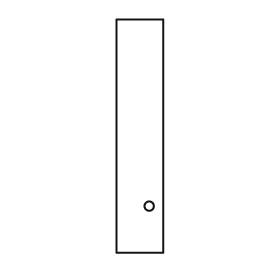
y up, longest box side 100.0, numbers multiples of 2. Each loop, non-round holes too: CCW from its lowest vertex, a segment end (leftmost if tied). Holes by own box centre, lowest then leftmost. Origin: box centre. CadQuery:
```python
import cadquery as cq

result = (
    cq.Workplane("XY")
    .moveTo(-10.0, -50.0)
    .lineTo(10.0, -50.0)
    .lineTo(10.0, 50.0)
    .lineTo(-10.0, 50.0)
    .close()
    .moveTo(4.0, -30.0)
    .circle(2.0)
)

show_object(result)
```